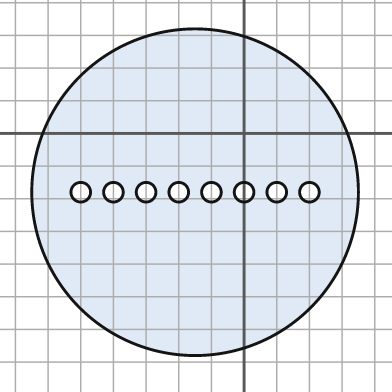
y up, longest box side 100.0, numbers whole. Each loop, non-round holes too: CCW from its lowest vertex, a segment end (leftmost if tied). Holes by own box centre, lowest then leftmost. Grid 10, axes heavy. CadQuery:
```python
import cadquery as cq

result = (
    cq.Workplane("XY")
    .moveTo(-15.0, -18.0)
    .circle(50.0)
    .moveTo(-50.0, -18.0)
    .circle(3.0)
    .moveTo(-40.0, -18.0)
    .circle(3.0)
    .moveTo(-30.0, -18.0)
    .circle(3.0)
    .moveTo(-20.0, -18.0)
    .circle(3.0)
    .moveTo(-10.0, -18.0)
    .circle(3.0)
    .moveTo(0.0, -18.0)
    .circle(3.0)
    .moveTo(10.0, -18.0)
    .circle(3.0)
    .moveTo(20.0, -18.0)
    .circle(3.0)
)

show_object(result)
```